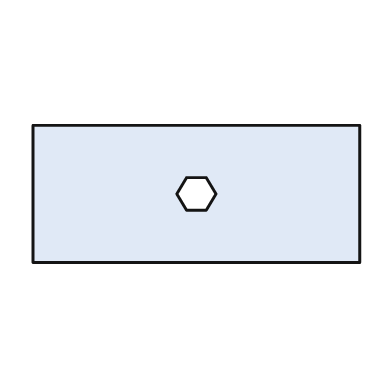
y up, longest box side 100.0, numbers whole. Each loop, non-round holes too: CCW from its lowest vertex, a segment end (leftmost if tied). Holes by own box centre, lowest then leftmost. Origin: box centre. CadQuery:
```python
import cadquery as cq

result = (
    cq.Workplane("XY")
    .moveTo(-50.0, -21.0)
    .lineTo(50.0, -21.0)
    .lineTo(50.0, 21.0)
    .lineTo(-50.0, 21.0)
    .close()
    .moveTo(-3.0, -5.0)
    .lineTo(3.0, -5.0)
    .lineTo(6.0, 0.0)
    .lineTo(3.0, 5.0)
    .lineTo(-3.0, 5.0)
    .lineTo(-6.0, 0.0)
    .close()
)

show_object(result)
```